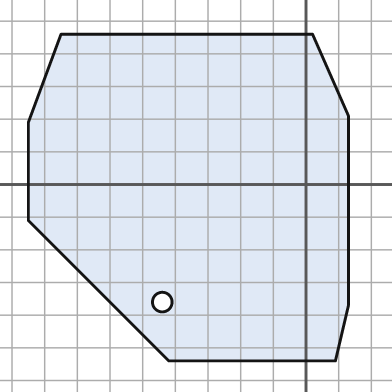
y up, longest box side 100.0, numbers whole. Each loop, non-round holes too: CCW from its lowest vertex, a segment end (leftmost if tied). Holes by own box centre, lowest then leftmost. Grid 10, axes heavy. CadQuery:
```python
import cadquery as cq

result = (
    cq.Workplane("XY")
    .moveTo(-42.0, -54.0)
    .lineTo(9.0, -54.0)
    .lineTo(13.0, -37.0)
    .lineTo(13.0, 21.0)
    .lineTo(2.0, 46.0)
    .lineTo(-75.0, 46.0)
    .lineTo(-85.0, 19.0)
    .lineTo(-85.0, -11.0)
    .close()
    .moveTo(-44.0, -36.0)
    .circle(3.0)
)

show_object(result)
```